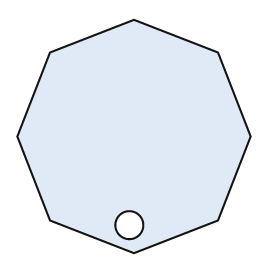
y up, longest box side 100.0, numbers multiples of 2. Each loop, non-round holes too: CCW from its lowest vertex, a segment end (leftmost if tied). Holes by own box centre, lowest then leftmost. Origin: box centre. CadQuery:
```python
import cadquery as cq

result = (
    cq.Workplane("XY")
    .moveTo(0.0, -50.0)
    .lineTo(36.0, -36.0)
    .lineTo(50.0, 0.0)
    .lineTo(36.0, 36.0)
    .lineTo(0.0, 50.0)
    .lineTo(-36.0, 36.0)
    .lineTo(-50.0, 0.0)
    .lineTo(-36.0, -36.0)
    .close()
    .moveTo(-2.0, -38.0)
    .circle(6.0)
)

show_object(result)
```